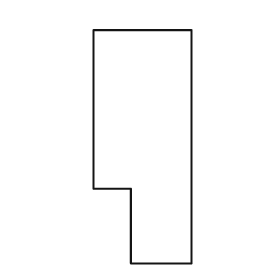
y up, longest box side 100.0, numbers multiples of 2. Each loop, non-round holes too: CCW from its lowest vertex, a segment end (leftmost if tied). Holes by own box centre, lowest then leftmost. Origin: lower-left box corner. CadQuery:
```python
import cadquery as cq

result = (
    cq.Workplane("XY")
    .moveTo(16.0, 0.0)
    .lineTo(42.0, 0.0)
    .lineTo(42.0, 100.0)
    .lineTo(0.0, 100.0)
    .lineTo(0.0, 32.0)
    .lineTo(16.0, 32.0)
    .close()
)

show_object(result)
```